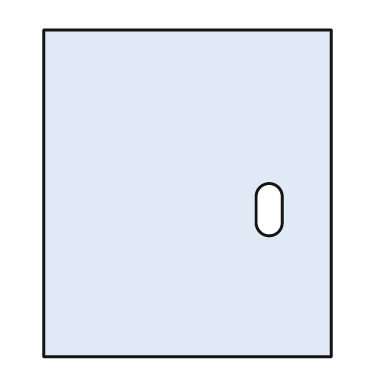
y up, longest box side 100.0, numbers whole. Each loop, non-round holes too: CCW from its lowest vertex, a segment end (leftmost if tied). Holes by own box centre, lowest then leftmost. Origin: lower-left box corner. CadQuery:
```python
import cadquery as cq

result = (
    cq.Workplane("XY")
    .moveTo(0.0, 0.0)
    .lineTo(88.0, 0.0)
    .lineTo(88.0, 100.0)
    .lineTo(0.0, 100.0)
    .close()
    .moveTo(65.0, 41.0)
    .threePointArc((69.0, 37.0), (73.0, 41.0))
    .lineTo(73.0, 49.0)
    .threePointArc((69.0, 53.0), (65.0, 49.0))
    .close()
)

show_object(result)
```